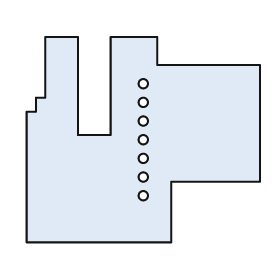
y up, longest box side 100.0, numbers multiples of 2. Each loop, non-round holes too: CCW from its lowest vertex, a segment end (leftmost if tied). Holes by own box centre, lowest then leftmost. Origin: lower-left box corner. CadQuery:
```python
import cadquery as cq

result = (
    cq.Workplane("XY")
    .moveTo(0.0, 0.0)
    .lineTo(62.0, 0.0)
    .lineTo(62.0, 26.0)
    .lineTo(100.0, 26.0)
    .lineTo(100.0, 76.0)
    .lineTo(56.0, 76.0)
    .lineTo(56.0, 88.0)
    .lineTo(36.0, 88.0)
    .lineTo(36.0, 46.0)
    .lineTo(22.0, 46.0)
    .lineTo(22.0, 88.0)
    .lineTo(8.0, 88.0)
    .lineTo(8.0, 62.0)
    .lineTo(4.0, 62.0)
    .lineTo(4.0, 56.0)
    .lineTo(0.0, 56.0)
    .close()
    .moveTo(50.0, 20.0)
    .circle(2.0)
    .moveTo(50.0, 28.0)
    .circle(2.0)
    .moveTo(50.0, 36.0)
    .circle(2.0)
    .moveTo(50.0, 44.0)
    .circle(2.0)
    .moveTo(50.0, 52.0)
    .circle(2.0)
    .moveTo(50.0, 60.0)
    .circle(2.0)
    .moveTo(50.0, 68.0)
    .circle(2.0)
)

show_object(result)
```